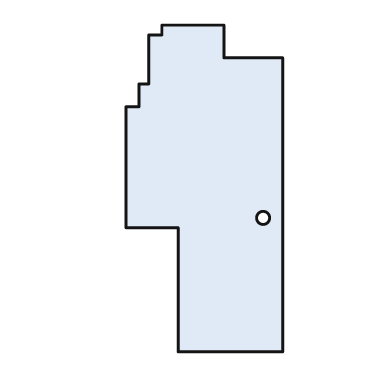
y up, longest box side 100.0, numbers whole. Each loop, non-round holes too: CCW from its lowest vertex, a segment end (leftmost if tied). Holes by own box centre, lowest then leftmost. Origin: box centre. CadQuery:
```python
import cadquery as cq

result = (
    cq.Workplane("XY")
    .moveTo(-8.0, -50.0)
    .lineTo(24.0, -50.0)
    .lineTo(24.0, 40.0)
    .lineTo(6.0, 40.0)
    .lineTo(6.0, 50.0)
    .lineTo(-13.0, 50.0)
    .lineTo(-13.0, 47.0)
    .lineTo(-17.0, 47.0)
    .lineTo(-17.0, 32.0)
    .lineTo(-20.0, 32.0)
    .lineTo(-20.0, 25.0)
    .lineTo(-24.0, 25.0)
    .lineTo(-24.0, -12.0)
    .lineTo(-8.0, -12.0)
    .close()
    .moveTo(18.0, -9.0)
    .circle(2.0)
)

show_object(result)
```